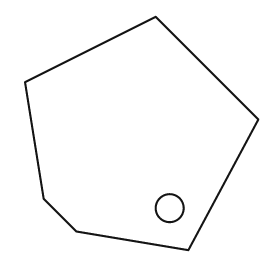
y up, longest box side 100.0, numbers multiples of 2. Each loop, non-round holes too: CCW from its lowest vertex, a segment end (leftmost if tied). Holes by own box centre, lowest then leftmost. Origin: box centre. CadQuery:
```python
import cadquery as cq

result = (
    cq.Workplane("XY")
    .moveTo(20.0, -50.0)
    .lineTo(50.0, 6.0)
    .lineTo(6.0, 50.0)
    .lineTo(-50.0, 22.0)
    .lineTo(-42.0, -28.0)
    .lineTo(-28.0, -42.0)
    .close()
    .moveTo(12.0, -32.0)
    .circle(6.0)
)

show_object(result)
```